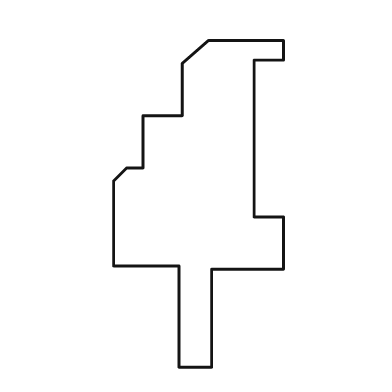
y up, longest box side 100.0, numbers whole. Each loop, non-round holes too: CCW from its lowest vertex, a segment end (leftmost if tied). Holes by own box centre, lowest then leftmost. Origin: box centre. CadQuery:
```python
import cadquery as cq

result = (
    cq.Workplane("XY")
    .moveTo(-6.0, -50.0)
    .lineTo(4.0, -50.0)
    .lineTo(4.0, -20.0)
    .lineTo(26.0, -20.0)
    .lineTo(26.0, -4.0)
    .lineTo(17.0, -4.0)
    .lineTo(17.0, 44.0)
    .lineTo(26.0, 44.0)
    .lineTo(26.0, 50.0)
    .lineTo(3.0, 50.0)
    .lineTo(-5.0, 43.0)
    .lineTo(-5.0, 27.0)
    .lineTo(-17.0, 27.0)
    .lineTo(-17.0, 11.0)
    .lineTo(-22.0, 11.0)
    .lineTo(-26.0, 7.0)
    .lineTo(-26.0, -19.0)
    .lineTo(-6.0, -19.0)
    .close()
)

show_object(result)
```